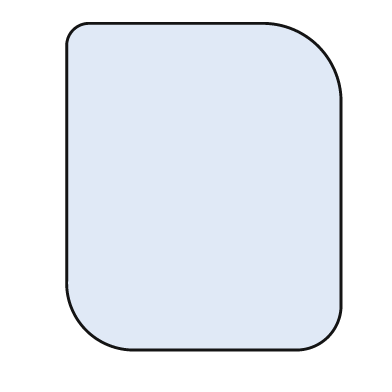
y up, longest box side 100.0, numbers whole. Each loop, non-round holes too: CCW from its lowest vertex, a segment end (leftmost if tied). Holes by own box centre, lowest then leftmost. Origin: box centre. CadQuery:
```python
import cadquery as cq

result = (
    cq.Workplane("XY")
    .moveTo(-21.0, -50.0)
    .lineTo(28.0, -50.0)
    .threePointArc((38.0, -46.0), (42.0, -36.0))
    .lineTo(42.0, 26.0)
    .threePointArc((35.0, 43.0), (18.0, 50.0))
    .lineTo(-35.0, 50.0)
    .threePointArc((-40.0, 48.0), (-42.0, 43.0))
    .lineTo(-42.0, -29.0)
    .threePointArc((-36.0, -44.0), (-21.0, -50.0))
    .close()
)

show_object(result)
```